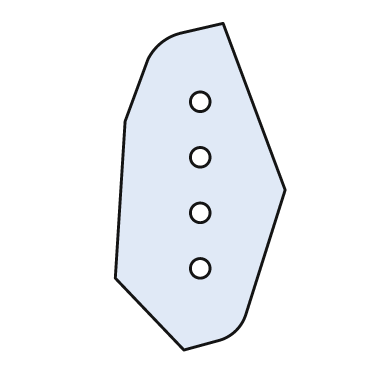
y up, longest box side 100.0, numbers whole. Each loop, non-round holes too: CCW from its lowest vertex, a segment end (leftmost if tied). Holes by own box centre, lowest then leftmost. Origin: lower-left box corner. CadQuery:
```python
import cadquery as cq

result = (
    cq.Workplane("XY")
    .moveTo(21.0, 0.0)
    .lineTo(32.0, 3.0)
    .threePointArc((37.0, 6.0), (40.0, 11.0))
    .lineTo(52.0, 49.0)
    .lineTo(33.0, 100.0)
    .lineTo(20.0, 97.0)
    .threePointArc((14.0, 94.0), (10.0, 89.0))
    .lineTo(3.0, 70.0)
    .lineTo(0.0, 22.0)
    .close()
    .moveTo(26.0, 25.0)
    .circle(3.0)
    .moveTo(26.0, 42.0)
    .circle(3.0)
    .moveTo(26.0, 59.0)
    .circle(3.0)
    .moveTo(26.0, 76.0)
    .circle(3.0)
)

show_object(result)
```